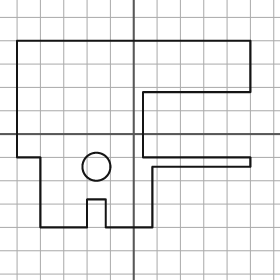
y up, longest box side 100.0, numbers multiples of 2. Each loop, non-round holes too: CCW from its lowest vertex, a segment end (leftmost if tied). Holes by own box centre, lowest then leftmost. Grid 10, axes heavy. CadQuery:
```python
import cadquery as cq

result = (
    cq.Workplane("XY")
    .moveTo(-40.0, -40.0)
    .lineTo(-20.0, -40.0)
    .lineTo(-20.0, -28.0)
    .lineTo(-12.0, -28.0)
    .lineTo(-12.0, -40.0)
    .lineTo(8.0, -40.0)
    .lineTo(8.0, -14.0)
    .lineTo(50.0, -14.0)
    .lineTo(50.0, -10.0)
    .lineTo(4.0, -10.0)
    .lineTo(4.0, 18.0)
    .lineTo(50.0, 18.0)
    .lineTo(50.0, 40.0)
    .lineTo(-50.0, 40.0)
    .lineTo(-50.0, -10.0)
    .lineTo(-40.0, -10.0)
    .close()
    .moveTo(-16.0, -14.0)
    .circle(6.0)
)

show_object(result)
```